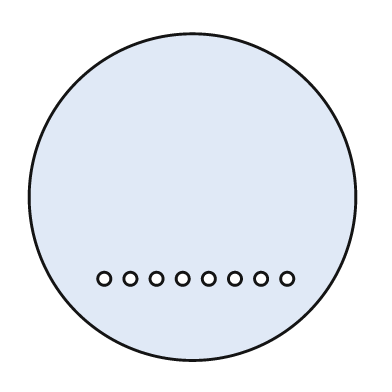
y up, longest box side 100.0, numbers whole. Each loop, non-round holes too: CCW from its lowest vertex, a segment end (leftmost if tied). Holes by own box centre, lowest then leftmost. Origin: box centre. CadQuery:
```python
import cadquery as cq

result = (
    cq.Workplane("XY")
    .moveTo(0.0, 0.0)
    .circle(50.0)
    .moveTo(-27.0, -25.0)
    .circle(2.0)
    .moveTo(-19.0, -25.0)
    .circle(2.0)
    .moveTo(-11.0, -25.0)
    .circle(2.0)
    .moveTo(-3.0, -25.0)
    .circle(2.0)
    .moveTo(5.0, -25.0)
    .circle(2.0)
    .moveTo(13.0, -25.0)
    .circle(2.0)
    .moveTo(21.0, -25.0)
    .circle(2.0)
    .moveTo(29.0, -25.0)
    .circle(2.0)
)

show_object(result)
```